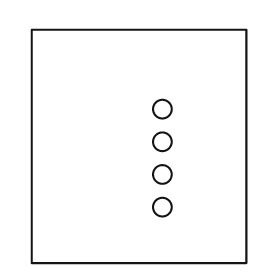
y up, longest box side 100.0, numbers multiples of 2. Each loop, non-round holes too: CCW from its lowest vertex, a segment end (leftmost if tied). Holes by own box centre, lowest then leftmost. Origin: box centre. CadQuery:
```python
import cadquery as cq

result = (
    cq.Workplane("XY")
    .moveTo(-46.0, -50.0)
    .lineTo(46.0, -50.0)
    .lineTo(46.0, 50.0)
    .lineTo(-46.0, 50.0)
    .close()
    .moveTo(10.0, -26.0)
    .circle(4.0)
    .moveTo(10.0, -12.0)
    .circle(4.0)
    .moveTo(10.0, 2.0)
    .circle(4.0)
    .moveTo(10.0, 16.0)
    .circle(4.0)
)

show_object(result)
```